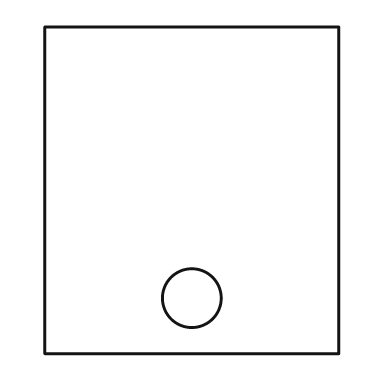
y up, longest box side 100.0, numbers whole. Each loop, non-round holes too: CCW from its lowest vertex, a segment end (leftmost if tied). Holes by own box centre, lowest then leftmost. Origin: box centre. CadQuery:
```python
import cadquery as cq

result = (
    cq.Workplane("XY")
    .moveTo(-45.0, -50.0)
    .lineTo(45.0, -50.0)
    .lineTo(45.0, 50.0)
    .lineTo(-45.0, 50.0)
    .close()
    .moveTo(0.0, -33.0)
    .circle(9.0)
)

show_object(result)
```